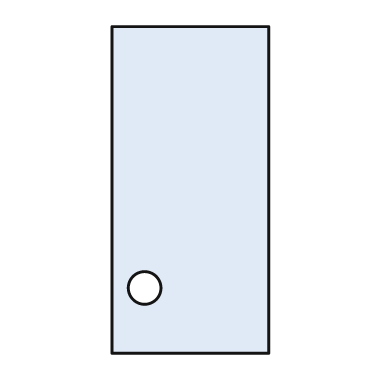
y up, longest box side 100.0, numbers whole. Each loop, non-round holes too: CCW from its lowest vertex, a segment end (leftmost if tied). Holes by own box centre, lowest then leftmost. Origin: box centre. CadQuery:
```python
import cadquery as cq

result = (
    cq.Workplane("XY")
    .moveTo(-24.0, -50.0)
    .lineTo(24.0, -50.0)
    .lineTo(24.0, 50.0)
    .lineTo(-24.0, 50.0)
    .close()
    .moveTo(-14.0, -30.0)
    .circle(5.0)
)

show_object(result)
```